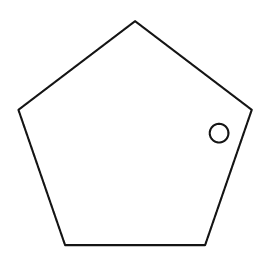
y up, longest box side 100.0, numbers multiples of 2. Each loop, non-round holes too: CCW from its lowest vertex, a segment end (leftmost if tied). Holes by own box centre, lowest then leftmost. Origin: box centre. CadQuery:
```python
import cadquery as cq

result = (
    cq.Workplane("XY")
    .moveTo(-30.0, -48.0)
    .lineTo(30.0, -48.0)
    .lineTo(50.0, 10.0)
    .lineTo(0.0, 48.0)
    .lineTo(-50.0, 10.0)
    .close()
    .moveTo(36.0, 0.0)
    .circle(4.0)
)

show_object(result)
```